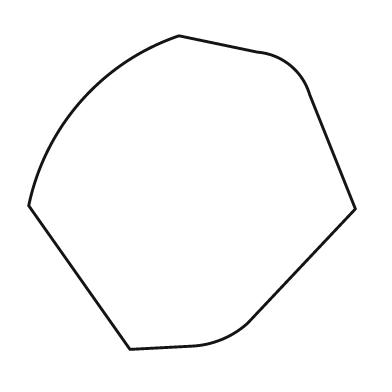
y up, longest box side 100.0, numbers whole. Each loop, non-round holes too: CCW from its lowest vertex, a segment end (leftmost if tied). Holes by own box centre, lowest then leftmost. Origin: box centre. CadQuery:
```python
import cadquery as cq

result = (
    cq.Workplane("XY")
    .moveTo(-19.0, -48.0)
    .lineTo(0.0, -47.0)
    .threePointArc((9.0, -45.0), (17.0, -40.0))
    .lineTo(50.0, -5.0)
    .lineTo(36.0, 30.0)
    .threePointArc((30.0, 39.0), (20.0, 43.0))
    .lineTo(-4.0, 48.0)
    .threePointArc((-34.0, 28.0), (-50.0, -4.0))
    .close()
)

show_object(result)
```